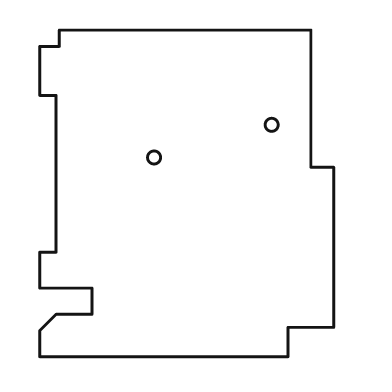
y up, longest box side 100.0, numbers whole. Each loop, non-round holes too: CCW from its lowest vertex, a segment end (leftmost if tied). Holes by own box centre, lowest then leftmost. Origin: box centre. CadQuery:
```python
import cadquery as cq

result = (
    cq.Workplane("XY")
    .moveTo(-45.0, -50.0)
    .lineTo(31.0, -50.0)
    .lineTo(31.0, -41.0)
    .lineTo(45.0, -41.0)
    .lineTo(45.0, 8.0)
    .lineTo(38.0, 8.0)
    .lineTo(38.0, 50.0)
    .lineTo(-39.0, 50.0)
    .lineTo(-39.0, 45.0)
    .lineTo(-45.0, 45.0)
    .lineTo(-45.0, 30.0)
    .lineTo(-40.0, 30.0)
    .lineTo(-40.0, -18.0)
    .lineTo(-45.0, -18.0)
    .lineTo(-45.0, -29.0)
    .lineTo(-29.0, -29.0)
    .lineTo(-29.0, -37.0)
    .lineTo(-40.0, -37.0)
    .lineTo(-45.0, -42.0)
    .close()
    .moveTo(-10.0, 11.0)
    .circle(2.0)
    .moveTo(26.0, 21.0)
    .circle(2.0)
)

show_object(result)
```